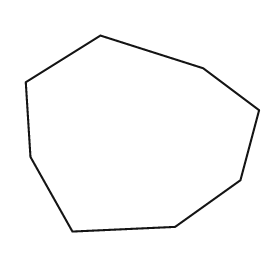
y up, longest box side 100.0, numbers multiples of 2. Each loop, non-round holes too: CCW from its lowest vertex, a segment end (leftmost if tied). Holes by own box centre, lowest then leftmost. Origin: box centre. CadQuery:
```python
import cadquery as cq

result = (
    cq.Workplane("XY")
    .moveTo(-30.0, -42.0)
    .lineTo(14.0, -40.0)
    .lineTo(42.0, -20.0)
    .lineTo(50.0, 10.0)
    .lineTo(26.0, 28.0)
    .lineTo(-18.0, 42.0)
    .lineTo(-50.0, 22.0)
    .lineTo(-48.0, -10.0)
    .close()
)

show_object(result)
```